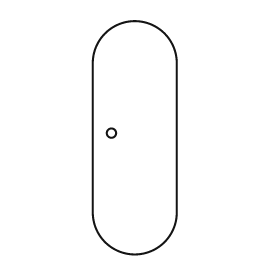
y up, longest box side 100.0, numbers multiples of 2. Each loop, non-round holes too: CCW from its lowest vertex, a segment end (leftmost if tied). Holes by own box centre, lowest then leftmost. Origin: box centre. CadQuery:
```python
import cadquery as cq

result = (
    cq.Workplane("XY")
    .moveTo(-18.0, -32.0)
    .threePointArc((0.0, -50.0), (18.0, -32.0))
    .lineTo(18.0, 32.0)
    .threePointArc((0.0, 50.0), (-18.0, 32.0))
    .close()
    .moveTo(-10.0, 2.0)
    .circle(2.0)
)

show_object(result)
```